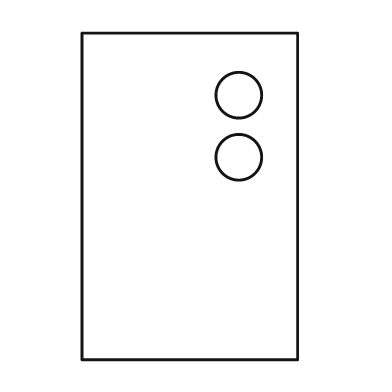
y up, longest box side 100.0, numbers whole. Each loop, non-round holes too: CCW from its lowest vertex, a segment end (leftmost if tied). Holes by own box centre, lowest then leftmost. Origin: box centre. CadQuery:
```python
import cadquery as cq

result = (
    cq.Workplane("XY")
    .moveTo(-33.0, -50.0)
    .lineTo(33.0, -50.0)
    .lineTo(33.0, 50.0)
    .lineTo(-33.0, 50.0)
    .close()
    .moveTo(15.0, 12.0)
    .circle(7.0)
    .moveTo(15.0, 31.0)
    .circle(7.0)
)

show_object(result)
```